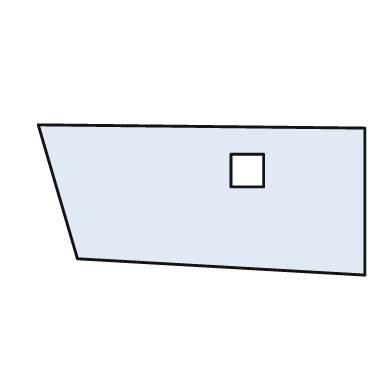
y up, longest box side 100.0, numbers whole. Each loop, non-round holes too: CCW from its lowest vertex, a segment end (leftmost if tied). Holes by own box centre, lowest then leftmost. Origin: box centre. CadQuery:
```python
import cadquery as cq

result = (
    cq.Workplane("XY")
    .moveTo(50.0, -23.0)
    .lineTo(50.0, 22.0)
    .lineTo(-50.0, 23.0)
    .lineTo(-38.0, -18.0)
    .close()
    .moveTo(9.0, 4.0)
    .lineTo(19.0, 4.0)
    .lineTo(19.0, 14.0)
    .lineTo(9.0, 14.0)
    .close()
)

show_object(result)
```